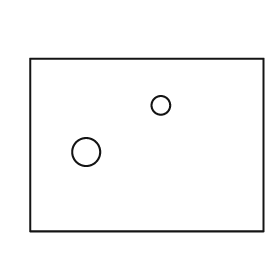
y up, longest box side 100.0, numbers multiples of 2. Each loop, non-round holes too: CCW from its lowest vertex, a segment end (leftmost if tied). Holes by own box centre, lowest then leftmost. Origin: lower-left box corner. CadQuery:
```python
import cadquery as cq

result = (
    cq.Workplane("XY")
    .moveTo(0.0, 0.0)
    .lineTo(100.0, 0.0)
    .lineTo(100.0, 74.0)
    .lineTo(0.0, 74.0)
    .close()
    .moveTo(24.0, 34.0)
    .circle(6.0)
    .moveTo(56.0, 54.0)
    .circle(4.0)
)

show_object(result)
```